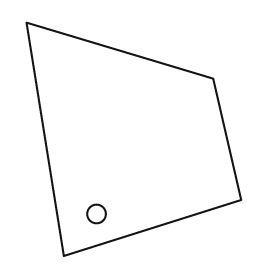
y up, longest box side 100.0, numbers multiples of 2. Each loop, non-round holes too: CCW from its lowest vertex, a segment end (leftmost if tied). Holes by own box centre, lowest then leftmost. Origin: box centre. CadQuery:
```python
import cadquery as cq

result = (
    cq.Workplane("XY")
    .moveTo(-30.0, -50.0)
    .lineTo(46.0, -26.0)
    .lineTo(34.0, 26.0)
    .lineTo(-46.0, 50.0)
    .close()
    .moveTo(-16.0, -32.0)
    .circle(4.0)
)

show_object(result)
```